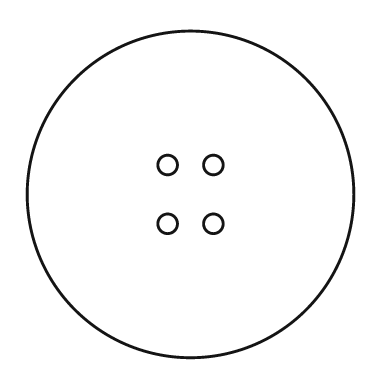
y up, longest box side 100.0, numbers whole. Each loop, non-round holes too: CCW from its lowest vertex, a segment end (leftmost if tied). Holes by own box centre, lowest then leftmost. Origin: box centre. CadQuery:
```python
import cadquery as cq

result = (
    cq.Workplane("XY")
    .moveTo(0.0, 0.0)
    .circle(50.0)
    .moveTo(-7.0, -9.0)
    .circle(3.0)
    .moveTo(7.0, -9.0)
    .circle(3.0)
    .moveTo(-7.0, 9.0)
    .circle(3.0)
    .moveTo(7.0, 9.0)
    .circle(3.0)
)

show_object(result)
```